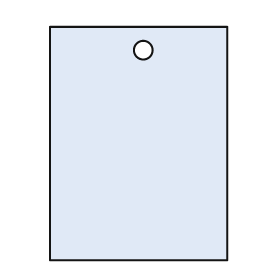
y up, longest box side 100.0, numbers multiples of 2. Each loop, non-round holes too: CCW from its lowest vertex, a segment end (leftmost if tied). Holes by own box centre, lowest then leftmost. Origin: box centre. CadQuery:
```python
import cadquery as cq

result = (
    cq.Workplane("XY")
    .moveTo(-38.0, -50.0)
    .lineTo(38.0, -50.0)
    .lineTo(38.0, 50.0)
    .lineTo(-38.0, 50.0)
    .close()
    .moveTo(2.0, 40.0)
    .circle(4.0)
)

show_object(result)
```